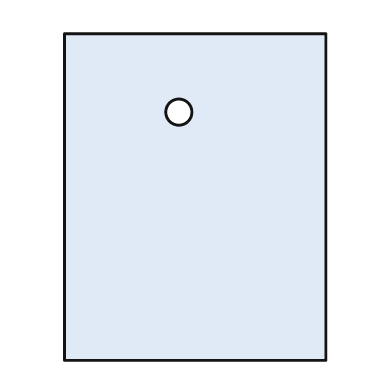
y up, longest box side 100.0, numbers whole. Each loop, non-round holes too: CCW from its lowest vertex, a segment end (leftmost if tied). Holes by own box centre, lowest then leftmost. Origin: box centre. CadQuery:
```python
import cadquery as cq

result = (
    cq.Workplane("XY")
    .moveTo(-40.0, -50.0)
    .lineTo(40.0, -50.0)
    .lineTo(40.0, 50.0)
    .lineTo(-40.0, 50.0)
    .close()
    .moveTo(-5.0, 26.0)
    .circle(4.0)
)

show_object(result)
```